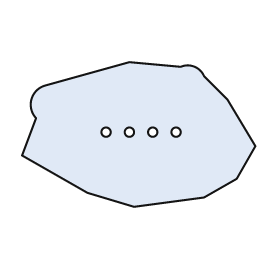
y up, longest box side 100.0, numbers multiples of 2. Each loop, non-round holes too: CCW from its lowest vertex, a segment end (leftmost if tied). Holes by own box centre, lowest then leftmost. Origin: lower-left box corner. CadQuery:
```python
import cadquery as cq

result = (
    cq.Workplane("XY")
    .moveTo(48.0, 0.0)
    .lineTo(78.0, 4.0)
    .lineTo(92.0, 12.0)
    .lineTo(100.0, 26.0)
    .lineTo(88.0, 46.0)
    .lineTo(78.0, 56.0)
    .threePointArc((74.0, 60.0), (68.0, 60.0))
    .lineTo(46.0, 62.0)
    .lineTo(10.0, 52.0)
    .threePointArc((4.0, 46.0), (6.0, 38.0))
    .lineTo(0.0, 22.0)
    .lineTo(28.0, 6.0)
    .close()
    .moveTo(36.0, 32.0)
    .circle(2.0)
    .moveTo(46.0, 32.0)
    .circle(2.0)
    .moveTo(56.0, 32.0)
    .circle(2.0)
    .moveTo(66.0, 32.0)
    .circle(2.0)
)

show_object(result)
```